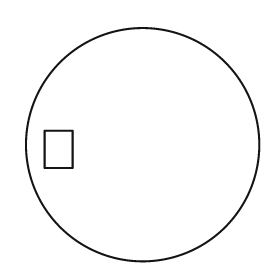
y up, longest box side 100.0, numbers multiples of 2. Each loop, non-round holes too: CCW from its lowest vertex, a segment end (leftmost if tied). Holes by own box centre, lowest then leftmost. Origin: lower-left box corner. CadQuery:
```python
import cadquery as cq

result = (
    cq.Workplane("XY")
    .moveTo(50.0, 50.0)
    .circle(50.0)
    .moveTo(8.0, 40.0)
    .lineTo(20.0, 40.0)
    .lineTo(20.0, 56.0)
    .lineTo(8.0, 56.0)
    .close()
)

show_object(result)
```